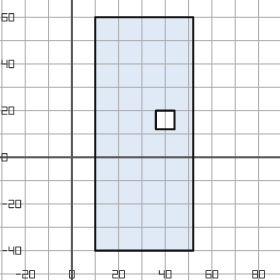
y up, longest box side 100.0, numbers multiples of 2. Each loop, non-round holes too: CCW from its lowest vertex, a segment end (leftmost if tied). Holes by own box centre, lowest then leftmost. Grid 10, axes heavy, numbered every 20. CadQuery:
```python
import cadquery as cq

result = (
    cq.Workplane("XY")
    .moveTo(10.0, -40.0)
    .lineTo(52.0, -40.0)
    .lineTo(52.0, 60.0)
    .lineTo(10.0, 60.0)
    .close()
    .moveTo(36.0, 12.0)
    .lineTo(44.0, 12.0)
    .lineTo(44.0, 20.0)
    .lineTo(36.0, 20.0)
    .close()
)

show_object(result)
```